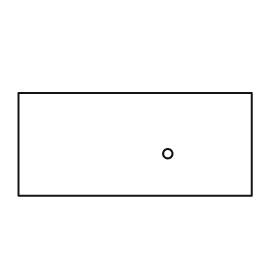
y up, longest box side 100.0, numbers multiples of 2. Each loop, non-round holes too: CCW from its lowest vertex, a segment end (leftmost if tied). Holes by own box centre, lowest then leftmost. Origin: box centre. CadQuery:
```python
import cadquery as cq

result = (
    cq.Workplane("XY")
    .moveTo(-50.0, -22.0)
    .lineTo(50.0, -22.0)
    .lineTo(50.0, 22.0)
    .lineTo(-50.0, 22.0)
    .close()
    .moveTo(14.0, -4.0)
    .circle(2.0)
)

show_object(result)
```